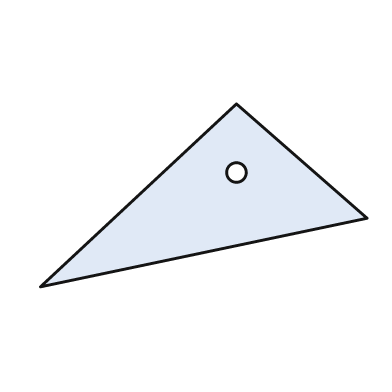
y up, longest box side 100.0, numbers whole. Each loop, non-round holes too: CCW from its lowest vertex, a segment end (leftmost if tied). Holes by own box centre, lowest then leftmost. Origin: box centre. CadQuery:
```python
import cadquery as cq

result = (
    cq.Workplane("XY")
    .moveTo(-50.0, -28.0)
    .lineTo(50.0, -7.0)
    .lineTo(10.0, 28.0)
    .close()
    .moveTo(10.0, 7.0)
    .circle(3.0)
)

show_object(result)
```